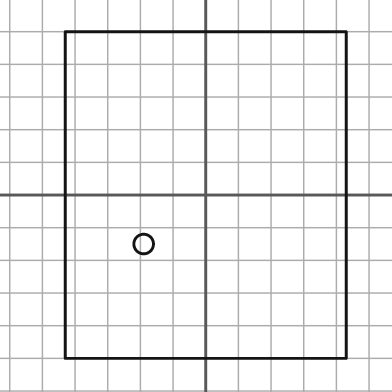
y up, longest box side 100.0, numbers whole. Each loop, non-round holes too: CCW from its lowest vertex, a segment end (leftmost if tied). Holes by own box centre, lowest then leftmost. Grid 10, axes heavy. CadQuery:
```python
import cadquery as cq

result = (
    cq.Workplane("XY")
    .moveTo(-43.0, -50.0)
    .lineTo(43.0, -50.0)
    .lineTo(43.0, 50.0)
    .lineTo(-43.0, 50.0)
    .close()
    .moveTo(-19.0, -15.0)
    .circle(3.0)
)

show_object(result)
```